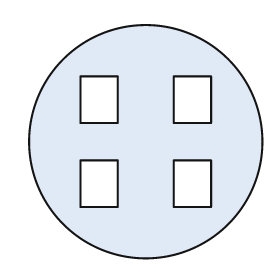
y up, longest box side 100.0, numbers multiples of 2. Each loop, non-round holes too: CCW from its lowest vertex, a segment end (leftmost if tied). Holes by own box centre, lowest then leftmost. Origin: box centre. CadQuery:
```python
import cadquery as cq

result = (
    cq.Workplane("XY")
    .moveTo(0.0, 0.0)
    .circle(50.0)
    .moveTo(-28.0, -28.0)
    .lineTo(-12.0, -28.0)
    .lineTo(-12.0, -8.0)
    .lineTo(-28.0, -8.0)
    .close()
    .moveTo(12.0, -28.0)
    .lineTo(28.0, -28.0)
    .lineTo(28.0, -8.0)
    .lineTo(12.0, -8.0)
    .close()
    .moveTo(-28.0, 8.0)
    .lineTo(-12.0, 8.0)
    .lineTo(-12.0, 28.0)
    .lineTo(-28.0, 28.0)
    .close()
    .moveTo(12.0, 8.0)
    .lineTo(28.0, 8.0)
    .lineTo(28.0, 28.0)
    .lineTo(12.0, 28.0)
    .close()
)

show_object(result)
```